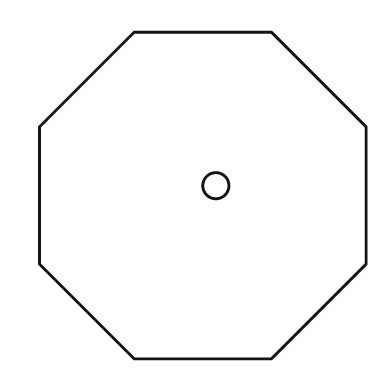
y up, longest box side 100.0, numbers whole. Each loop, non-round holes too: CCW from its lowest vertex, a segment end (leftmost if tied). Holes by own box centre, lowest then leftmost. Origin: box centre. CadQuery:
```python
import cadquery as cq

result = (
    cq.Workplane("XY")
    .moveTo(-21.0, -50.0)
    .lineTo(21.0, -50.0)
    .lineTo(50.0, -21.0)
    .lineTo(50.0, 21.0)
    .lineTo(21.0, 50.0)
    .lineTo(-21.0, 50.0)
    .lineTo(-50.0, 21.0)
    .lineTo(-50.0, -21.0)
    .close()
    .moveTo(4.0, 3.0)
    .circle(4.0)
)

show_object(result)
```